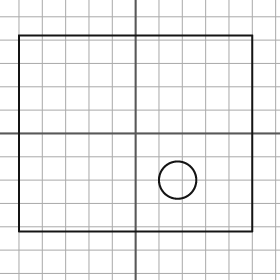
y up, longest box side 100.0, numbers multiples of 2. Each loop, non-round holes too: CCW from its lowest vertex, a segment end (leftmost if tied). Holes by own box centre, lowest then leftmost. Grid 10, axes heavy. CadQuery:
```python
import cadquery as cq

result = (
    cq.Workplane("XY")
    .moveTo(-50.0, -42.0)
    .lineTo(50.0, -42.0)
    .lineTo(50.0, 42.0)
    .lineTo(-50.0, 42.0)
    .close()
    .moveTo(18.0, -20.0)
    .circle(8.0)
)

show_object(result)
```